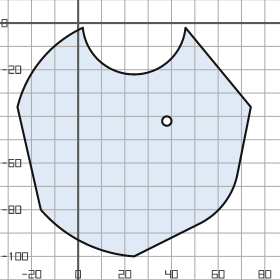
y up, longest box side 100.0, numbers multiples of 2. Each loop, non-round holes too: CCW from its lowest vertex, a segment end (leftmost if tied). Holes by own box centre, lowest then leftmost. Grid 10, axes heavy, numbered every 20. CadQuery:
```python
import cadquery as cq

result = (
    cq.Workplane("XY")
    .moveTo(24.0, -100.0)
    .lineTo(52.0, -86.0)
    .threePointArc((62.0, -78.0), (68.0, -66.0))
    .lineTo(74.0, -36.0)
    .lineTo(46.0, -2.0)
    .threePointArc((24.0, -22.0), (2.0, -2.0))
    .threePointArc((-16.0, -16.0), (-26.0, -36.0))
    .lineTo(-16.0, -80.0)
    .threePointArc((2.0, -94.0), (24.0, -100.0))
    .close()
    .moveTo(38.0, -42.0)
    .circle(2.0)
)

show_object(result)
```